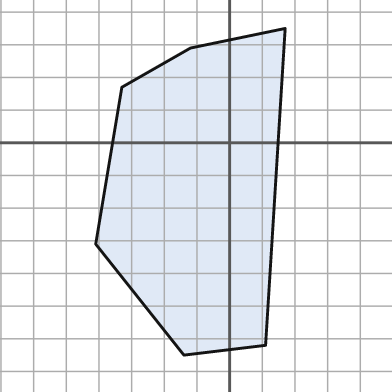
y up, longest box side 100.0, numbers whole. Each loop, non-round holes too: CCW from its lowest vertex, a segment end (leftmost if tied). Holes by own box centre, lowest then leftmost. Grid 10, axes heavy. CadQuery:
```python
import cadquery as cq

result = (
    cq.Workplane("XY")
    .moveTo(-14.0, -65.0)
    .lineTo(11.0, -62.0)
    .lineTo(17.0, 35.0)
    .lineTo(-12.0, 29.0)
    .lineTo(-33.0, 17.0)
    .lineTo(-41.0, -31.0)
    .close()
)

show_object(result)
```